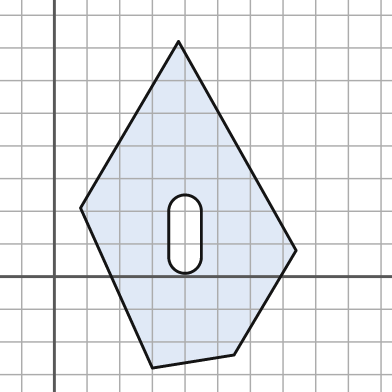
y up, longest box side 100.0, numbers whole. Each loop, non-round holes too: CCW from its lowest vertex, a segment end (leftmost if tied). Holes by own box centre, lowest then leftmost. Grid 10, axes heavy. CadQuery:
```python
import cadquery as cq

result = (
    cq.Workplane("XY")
    .moveTo(30.0, -28.0)
    .lineTo(55.0, -24.0)
    .lineTo(74.0, 8.0)
    .lineTo(38.0, 72.0)
    .lineTo(8.0, 21.0)
    .close()
    .moveTo(35.0, 6.0)
    .threePointArc((40.0, 1.0), (45.0, 6.0))
    .lineTo(45.0, 20.0)
    .threePointArc((40.0, 25.0), (35.0, 20.0))
    .close()
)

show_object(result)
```